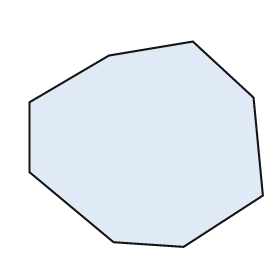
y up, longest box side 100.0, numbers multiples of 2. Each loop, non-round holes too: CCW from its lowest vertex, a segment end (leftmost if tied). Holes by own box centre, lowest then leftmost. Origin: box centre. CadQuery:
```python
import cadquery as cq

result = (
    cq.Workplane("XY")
    .moveTo(16.0, -44.0)
    .lineTo(50.0, -22.0)
    .lineTo(46.0, 20.0)
    .lineTo(20.0, 44.0)
    .lineTo(-16.0, 38.0)
    .lineTo(-50.0, 18.0)
    .lineTo(-50.0, -12.0)
    .lineTo(-14.0, -42.0)
    .close()
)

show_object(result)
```